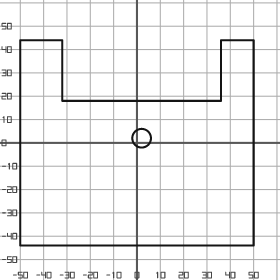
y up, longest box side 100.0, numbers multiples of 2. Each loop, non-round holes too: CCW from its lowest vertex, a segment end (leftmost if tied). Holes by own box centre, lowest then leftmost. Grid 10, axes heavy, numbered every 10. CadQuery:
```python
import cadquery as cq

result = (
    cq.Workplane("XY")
    .moveTo(-50.0, -44.0)
    .lineTo(50.0, -44.0)
    .lineTo(50.0, 44.0)
    .lineTo(36.0, 44.0)
    .lineTo(36.0, 18.0)
    .lineTo(-32.0, 18.0)
    .lineTo(-32.0, 44.0)
    .lineTo(-50.0, 44.0)
    .close()
    .moveTo(2.0, 2.0)
    .circle(4.0)
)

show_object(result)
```